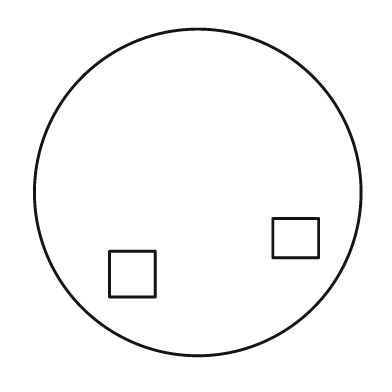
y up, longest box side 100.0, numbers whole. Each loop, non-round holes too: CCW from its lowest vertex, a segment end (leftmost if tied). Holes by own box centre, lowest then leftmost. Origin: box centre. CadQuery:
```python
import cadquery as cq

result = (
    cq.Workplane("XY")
    .moveTo(0.0, 0.0)
    .circle(50.0)
    .moveTo(-27.0, -32.0)
    .lineTo(-13.0, -32.0)
    .lineTo(-13.0, -18.0)
    .lineTo(-27.0, -18.0)
    .close()
    .moveTo(23.0, -20.0)
    .lineTo(37.0, -20.0)
    .lineTo(37.0, -8.0)
    .lineTo(23.0, -8.0)
    .close()
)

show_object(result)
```